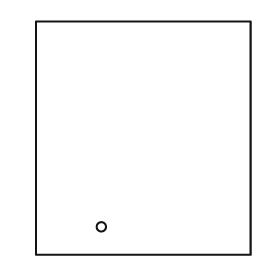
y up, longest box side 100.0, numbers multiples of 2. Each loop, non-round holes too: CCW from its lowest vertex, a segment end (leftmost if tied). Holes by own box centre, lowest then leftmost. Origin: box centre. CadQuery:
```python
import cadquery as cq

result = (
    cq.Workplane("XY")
    .moveTo(-46.0, -50.0)
    .lineTo(46.0, -50.0)
    .lineTo(46.0, 50.0)
    .lineTo(-46.0, 50.0)
    .close()
    .moveTo(-18.0, -38.0)
    .circle(2.0)
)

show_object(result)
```